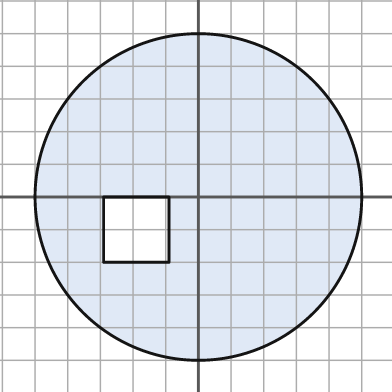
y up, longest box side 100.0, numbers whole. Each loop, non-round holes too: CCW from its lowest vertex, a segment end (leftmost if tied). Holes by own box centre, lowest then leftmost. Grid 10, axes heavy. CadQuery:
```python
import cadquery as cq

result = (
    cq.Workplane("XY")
    .moveTo(0.0, 0.0)
    .circle(50.0)
    .moveTo(-29.0, -20.0)
    .lineTo(-9.0, -20.0)
    .lineTo(-9.0, 0.0)
    .lineTo(-29.0, 0.0)
    .close()
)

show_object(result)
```